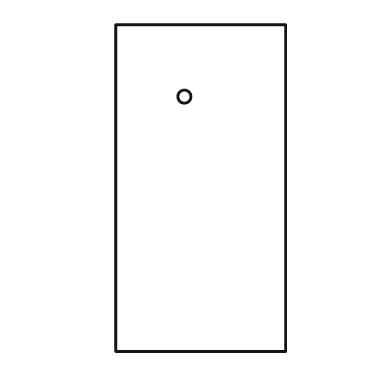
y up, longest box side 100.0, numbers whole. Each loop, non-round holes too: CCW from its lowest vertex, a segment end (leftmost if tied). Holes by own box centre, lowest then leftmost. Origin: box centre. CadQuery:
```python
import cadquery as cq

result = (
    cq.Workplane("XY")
    .moveTo(-26.0, -50.0)
    .lineTo(26.0, -50.0)
    .lineTo(26.0, 50.0)
    .lineTo(-26.0, 50.0)
    .close()
    .moveTo(-5.0, 28.0)
    .circle(2.0)
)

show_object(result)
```